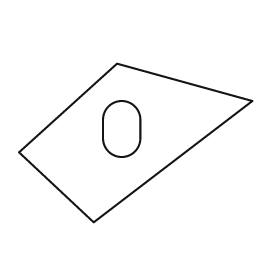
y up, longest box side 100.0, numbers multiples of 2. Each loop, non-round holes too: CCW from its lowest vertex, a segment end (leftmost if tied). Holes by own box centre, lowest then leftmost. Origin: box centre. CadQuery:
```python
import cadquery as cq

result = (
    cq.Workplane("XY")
    .moveTo(-18.0, -34.0)
    .lineTo(50.0, 18.0)
    .lineTo(-8.0, 34.0)
    .lineTo(-50.0, -4.0)
    .close()
    .moveTo(-14.0, 2.0)
    .threePointArc((-6.0, -6.0), (2.0, 2.0))
    .lineTo(2.0, 10.0)
    .threePointArc((-6.0, 18.0), (-14.0, 10.0))
    .close()
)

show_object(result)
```